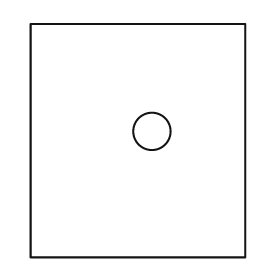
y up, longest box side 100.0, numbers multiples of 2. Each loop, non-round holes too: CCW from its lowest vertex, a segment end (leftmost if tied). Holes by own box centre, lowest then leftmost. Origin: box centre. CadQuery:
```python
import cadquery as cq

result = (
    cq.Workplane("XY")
    .moveTo(-46.0, -50.0)
    .lineTo(46.0, -50.0)
    .lineTo(46.0, 50.0)
    .lineTo(-46.0, 50.0)
    .close()
    .moveTo(6.0, 4.0)
    .circle(8.0)
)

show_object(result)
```